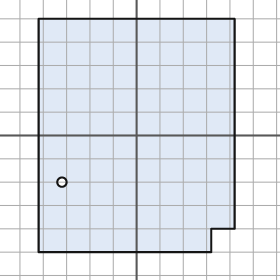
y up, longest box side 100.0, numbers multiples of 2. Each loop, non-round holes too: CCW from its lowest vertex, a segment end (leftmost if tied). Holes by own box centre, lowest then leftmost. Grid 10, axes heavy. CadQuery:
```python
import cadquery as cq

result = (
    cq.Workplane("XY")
    .moveTo(-42.0, -50.0)
    .lineTo(32.0, -50.0)
    .lineTo(32.0, -40.0)
    .lineTo(42.0, -40.0)
    .lineTo(42.0, 50.0)
    .lineTo(-42.0, 50.0)
    .close()
    .moveTo(-32.0, -20.0)
    .circle(2.0)
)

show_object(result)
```